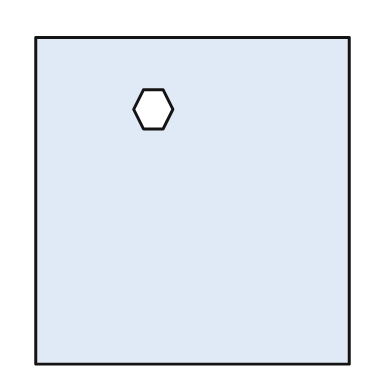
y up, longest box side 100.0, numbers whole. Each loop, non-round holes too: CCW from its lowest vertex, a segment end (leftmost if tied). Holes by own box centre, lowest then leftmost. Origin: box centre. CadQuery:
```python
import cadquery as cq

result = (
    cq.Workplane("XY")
    .moveTo(-48.0, -50.0)
    .lineTo(48.0, -50.0)
    .lineTo(48.0, 50.0)
    .lineTo(-48.0, 50.0)
    .close()
    .moveTo(-15.0, 22.0)
    .lineTo(-9.0, 22.0)
    .lineTo(-6.0, 28.0)
    .lineTo(-9.0, 34.0)
    .lineTo(-15.0, 34.0)
    .lineTo(-18.0, 28.0)
    .close()
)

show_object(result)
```